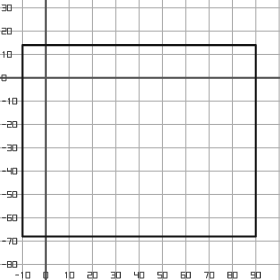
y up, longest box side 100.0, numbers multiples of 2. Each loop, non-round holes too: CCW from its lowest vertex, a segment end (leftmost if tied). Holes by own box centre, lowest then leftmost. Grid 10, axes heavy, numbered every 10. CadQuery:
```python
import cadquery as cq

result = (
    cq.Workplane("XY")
    .moveTo(-10.0, -68.0)
    .lineTo(90.0, -68.0)
    .lineTo(90.0, 14.0)
    .lineTo(-10.0, 14.0)
    .close()
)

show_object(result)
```